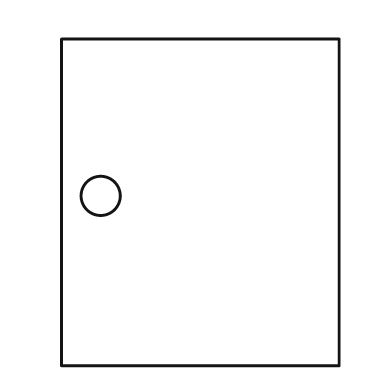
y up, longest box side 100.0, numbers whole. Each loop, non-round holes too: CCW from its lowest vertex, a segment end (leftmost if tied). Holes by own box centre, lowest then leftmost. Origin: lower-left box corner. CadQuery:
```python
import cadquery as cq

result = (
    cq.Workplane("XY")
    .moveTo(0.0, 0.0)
    .lineTo(85.0, 0.0)
    .lineTo(85.0, 100.0)
    .lineTo(0.0, 100.0)
    .close()
    .moveTo(12.0, 52.0)
    .circle(6.0)
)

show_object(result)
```